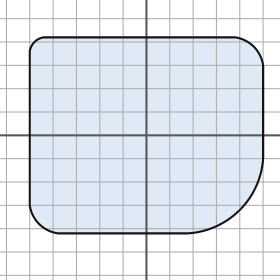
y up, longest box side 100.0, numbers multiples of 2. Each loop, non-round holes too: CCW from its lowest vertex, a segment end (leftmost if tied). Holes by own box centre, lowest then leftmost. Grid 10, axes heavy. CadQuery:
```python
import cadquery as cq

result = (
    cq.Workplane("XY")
    .moveTo(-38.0, -42.0)
    .lineTo(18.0, -42.0)
    .threePointArc((40.0, -32.0), (50.0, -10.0))
    .lineTo(50.0, 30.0)
    .threePointArc((46.0, 38.0), (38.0, 42.0))
    .lineTo(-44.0, 42.0)
    .threePointArc((-48.0, 40.0), (-50.0, 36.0))
    .lineTo(-50.0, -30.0)
    .threePointArc((-46.0, -38.0), (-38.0, -42.0))
    .close()
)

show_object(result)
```